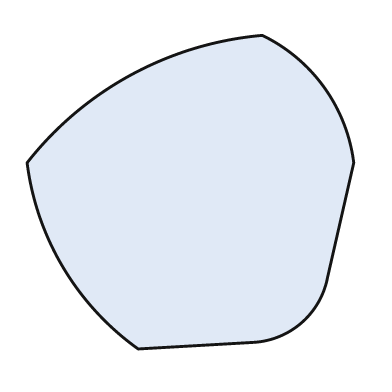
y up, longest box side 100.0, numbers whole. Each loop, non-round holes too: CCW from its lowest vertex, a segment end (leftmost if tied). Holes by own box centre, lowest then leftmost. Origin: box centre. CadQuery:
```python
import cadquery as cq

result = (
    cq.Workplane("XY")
    .moveTo(-16.0, -48.0)
    .lineTo(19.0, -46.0)
    .threePointArc((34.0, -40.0), (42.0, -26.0))
    .lineTo(50.0, 9.0)
    .threePointArc((41.0, 32.0), (22.0, 48.0))
    .threePointArc((-18.0, 36.0), (-50.0, 9.0))
    .threePointArc((-39.0, -23.0), (-16.0, -48.0))
    .close()
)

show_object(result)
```